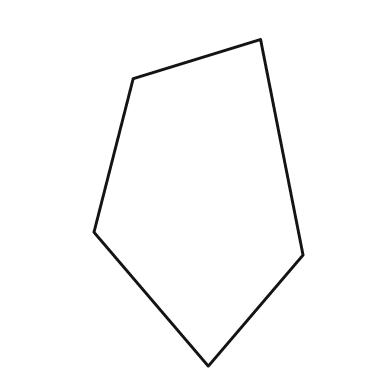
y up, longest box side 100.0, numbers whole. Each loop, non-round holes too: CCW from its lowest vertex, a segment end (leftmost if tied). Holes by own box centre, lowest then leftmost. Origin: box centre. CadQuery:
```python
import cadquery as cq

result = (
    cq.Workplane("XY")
    .moveTo(3.0, -50.0)
    .lineTo(32.0, -16.0)
    .lineTo(19.0, 50.0)
    .lineTo(-20.0, 38.0)
    .lineTo(-32.0, -9.0)
    .close()
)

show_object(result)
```